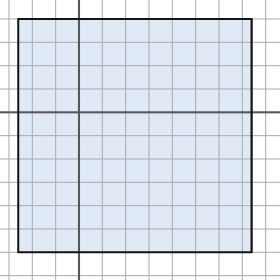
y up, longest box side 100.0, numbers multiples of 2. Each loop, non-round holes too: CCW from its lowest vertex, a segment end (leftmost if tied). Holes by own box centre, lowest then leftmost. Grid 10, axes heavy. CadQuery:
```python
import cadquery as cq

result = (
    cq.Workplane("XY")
    .moveTo(-26.0, -60.0)
    .lineTo(74.0, -60.0)
    .lineTo(74.0, 40.0)
    .lineTo(-26.0, 40.0)
    .close()
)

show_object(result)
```